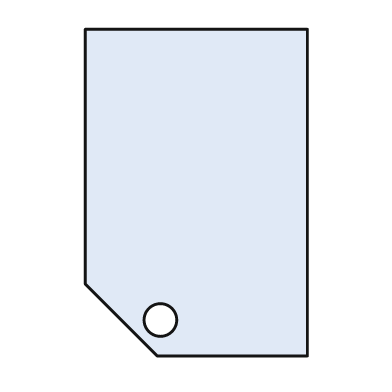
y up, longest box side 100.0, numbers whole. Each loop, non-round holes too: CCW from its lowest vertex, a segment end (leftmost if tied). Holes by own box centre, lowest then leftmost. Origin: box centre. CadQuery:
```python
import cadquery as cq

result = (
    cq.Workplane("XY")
    .moveTo(-12.0, -50.0)
    .lineTo(34.0, -50.0)
    .lineTo(34.0, 50.0)
    .lineTo(-34.0, 50.0)
    .lineTo(-34.0, -28.0)
    .close()
    .moveTo(-11.0, -39.0)
    .circle(5.0)
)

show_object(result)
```